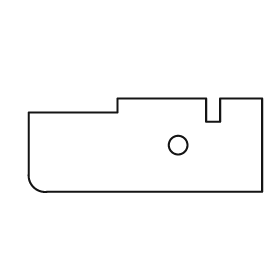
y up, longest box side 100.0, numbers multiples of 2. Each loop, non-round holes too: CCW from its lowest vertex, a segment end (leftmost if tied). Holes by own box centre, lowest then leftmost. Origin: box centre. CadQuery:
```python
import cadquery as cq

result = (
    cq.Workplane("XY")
    .moveTo(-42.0, -20.0)
    .lineTo(50.0, -20.0)
    .lineTo(50.0, 20.0)
    .lineTo(32.0, 20.0)
    .lineTo(32.0, 10.0)
    .lineTo(26.0, 10.0)
    .lineTo(26.0, 20.0)
    .lineTo(-12.0, 20.0)
    .lineTo(-12.0, 14.0)
    .lineTo(-50.0, 14.0)
    .lineTo(-50.0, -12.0)
    .threePointArc((-48.0, -18.0), (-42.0, -20.0))
    .close()
    .moveTo(14.0, 0.0)
    .circle(4.0)
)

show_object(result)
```